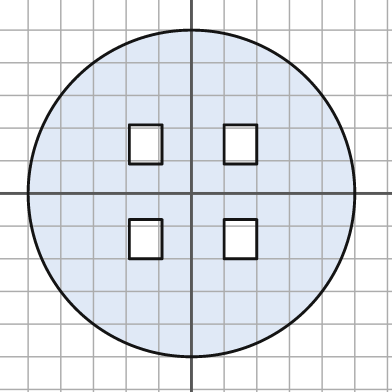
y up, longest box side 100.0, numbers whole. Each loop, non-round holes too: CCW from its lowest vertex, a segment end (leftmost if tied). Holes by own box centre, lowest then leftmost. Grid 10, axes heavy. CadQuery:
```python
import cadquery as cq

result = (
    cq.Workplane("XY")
    .moveTo(0.0, 0.0)
    .circle(50.0)
    .moveTo(-19.0, -20.0)
    .lineTo(-9.0, -20.0)
    .lineTo(-9.0, -8.0)
    .lineTo(-19.0, -8.0)
    .close()
    .moveTo(10.0, -20.0)
    .lineTo(20.0, -20.0)
    .lineTo(20.0, -8.0)
    .lineTo(10.0, -8.0)
    .close()
    .moveTo(-19.0, 9.0)
    .lineTo(-9.0, 9.0)
    .lineTo(-9.0, 21.0)
    .lineTo(-19.0, 21.0)
    .close()
    .moveTo(10.0, 9.0)
    .lineTo(20.0, 9.0)
    .lineTo(20.0, 21.0)
    .lineTo(10.0, 21.0)
    .close()
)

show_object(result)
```